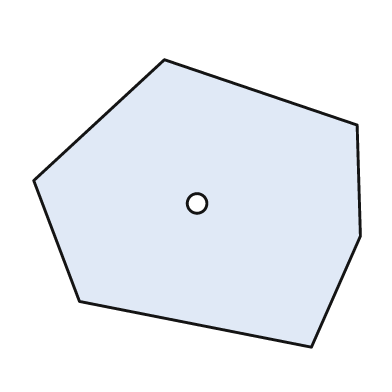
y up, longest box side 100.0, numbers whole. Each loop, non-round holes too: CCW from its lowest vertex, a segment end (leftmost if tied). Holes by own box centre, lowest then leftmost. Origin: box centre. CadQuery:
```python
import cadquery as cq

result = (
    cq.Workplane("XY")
    .moveTo(35.0, -44.0)
    .lineTo(50.0, -10.0)
    .lineTo(49.0, 24.0)
    .lineTo(-10.0, 44.0)
    .lineTo(-50.0, 7.0)
    .lineTo(-36.0, -30.0)
    .close()
    .moveTo(0.0, 0.0)
    .circle(3.0)
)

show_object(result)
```